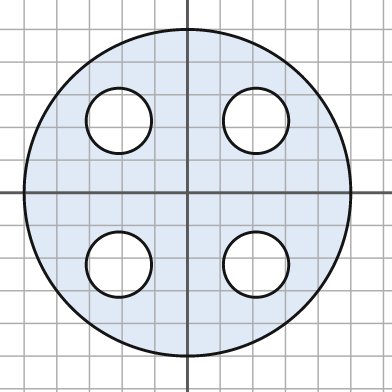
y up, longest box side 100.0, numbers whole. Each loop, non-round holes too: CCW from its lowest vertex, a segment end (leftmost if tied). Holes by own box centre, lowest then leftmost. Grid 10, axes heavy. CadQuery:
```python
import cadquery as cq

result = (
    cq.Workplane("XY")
    .moveTo(0.0, 0.0)
    .circle(50.0)
    .moveTo(-21.0, -22.0)
    .circle(10.0)
    .moveTo(21.0, -22.0)
    .circle(10.0)
    .moveTo(-21.0, 22.0)
    .circle(10.0)
    .moveTo(21.0, 22.0)
    .circle(10.0)
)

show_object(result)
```